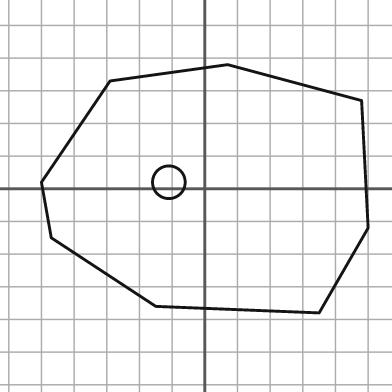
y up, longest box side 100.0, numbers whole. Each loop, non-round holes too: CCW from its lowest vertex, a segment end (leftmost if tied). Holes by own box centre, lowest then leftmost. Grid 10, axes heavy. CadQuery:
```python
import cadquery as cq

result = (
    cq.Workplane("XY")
    .moveTo(35.0, -38.0)
    .lineTo(50.0, -12.0)
    .lineTo(48.0, 27.0)
    .lineTo(7.0, 38.0)
    .lineTo(-29.0, 33.0)
    .lineTo(-50.0, 2.0)
    .lineTo(-47.0, -15.0)
    .lineTo(-15.0, -36.0)
    .close()
    .moveTo(-11.0, 2.0)
    .circle(5.0)
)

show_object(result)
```